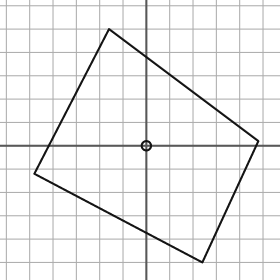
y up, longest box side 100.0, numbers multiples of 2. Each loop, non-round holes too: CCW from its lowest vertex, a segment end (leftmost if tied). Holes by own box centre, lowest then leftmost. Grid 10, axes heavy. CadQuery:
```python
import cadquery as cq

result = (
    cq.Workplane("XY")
    .moveTo(24.0, -50.0)
    .lineTo(48.0, 2.0)
    .lineTo(-16.0, 50.0)
    .lineTo(-48.0, -12.0)
    .close()
    .moveTo(0.0, 0.0)
    .circle(2.0)
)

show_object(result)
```